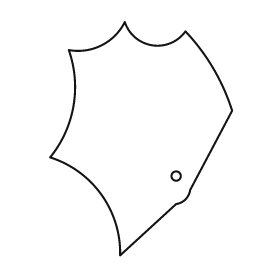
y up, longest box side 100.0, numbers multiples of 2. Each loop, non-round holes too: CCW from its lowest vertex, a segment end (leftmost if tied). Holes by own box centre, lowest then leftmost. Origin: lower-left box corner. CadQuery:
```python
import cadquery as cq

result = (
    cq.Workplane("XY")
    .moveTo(30.0, 0.0)
    .lineTo(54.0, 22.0)
    .threePointArc((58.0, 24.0), (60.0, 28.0))
    .lineTo(78.0, 62.0)
    .threePointArc((70.0, 80.0), (58.0, 96.0))
    .threePointArc((44.0, 90.0), (32.0, 100.0))
    .threePointArc((22.0, 90.0), (8.0, 88.0))
    .threePointArc((10.0, 64.0), (0.0, 42.0))
    .threePointArc((22.0, 26.0), (30.0, 0.0))
    .close()
    .moveTo(54.0, 34.0)
    .circle(2.0)
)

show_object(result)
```